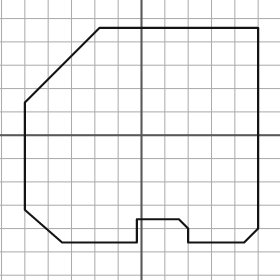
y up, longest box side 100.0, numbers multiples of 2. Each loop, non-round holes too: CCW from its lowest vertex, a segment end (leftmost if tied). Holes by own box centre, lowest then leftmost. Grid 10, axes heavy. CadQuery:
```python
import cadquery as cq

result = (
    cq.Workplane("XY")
    .moveTo(-34.0, -46.0)
    .lineTo(-2.0, -46.0)
    .lineTo(-2.0, -36.0)
    .lineTo(16.0, -36.0)
    .lineTo(20.0, -40.0)
    .lineTo(20.0, -46.0)
    .lineTo(44.0, -46.0)
    .lineTo(50.0, -40.0)
    .lineTo(50.0, 46.0)
    .lineTo(-18.0, 46.0)
    .lineTo(-50.0, 14.0)
    .lineTo(-50.0, -32.0)
    .close()
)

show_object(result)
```